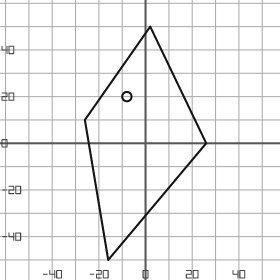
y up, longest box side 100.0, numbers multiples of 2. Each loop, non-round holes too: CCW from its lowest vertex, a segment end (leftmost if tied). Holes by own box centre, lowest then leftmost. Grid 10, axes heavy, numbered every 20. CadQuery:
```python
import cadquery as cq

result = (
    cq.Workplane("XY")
    .moveTo(-16.0, -50.0)
    .lineTo(26.0, 0.0)
    .lineTo(2.0, 50.0)
    .lineTo(-26.0, 10.0)
    .close()
    .moveTo(-8.0, 20.0)
    .circle(2.0)
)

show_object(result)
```